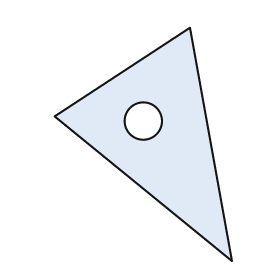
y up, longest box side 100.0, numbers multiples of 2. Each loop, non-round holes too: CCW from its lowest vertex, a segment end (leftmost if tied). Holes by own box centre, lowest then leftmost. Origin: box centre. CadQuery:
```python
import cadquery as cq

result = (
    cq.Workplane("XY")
    .moveTo(38.0, -50.0)
    .lineTo(20.0, 50.0)
    .lineTo(-38.0, 12.0)
    .close()
    .moveTo(0.0, 10.0)
    .circle(8.0)
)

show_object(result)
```